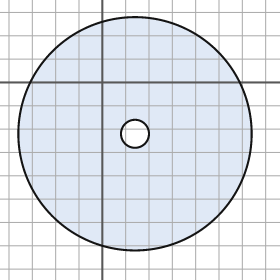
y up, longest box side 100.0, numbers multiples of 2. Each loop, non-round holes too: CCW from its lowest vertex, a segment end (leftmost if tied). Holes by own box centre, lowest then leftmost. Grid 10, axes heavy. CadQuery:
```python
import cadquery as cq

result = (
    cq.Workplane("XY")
    .moveTo(14.0, -22.0)
    .circle(50.0)
    .moveTo(14.0, -22.0)
    .circle(6.0)
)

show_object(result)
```